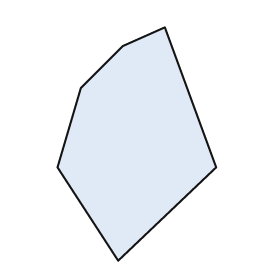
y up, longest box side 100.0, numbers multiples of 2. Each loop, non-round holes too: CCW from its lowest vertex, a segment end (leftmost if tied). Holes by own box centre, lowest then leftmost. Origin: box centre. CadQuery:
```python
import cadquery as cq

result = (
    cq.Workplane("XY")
    .moveTo(-8.0, -50.0)
    .lineTo(34.0, -10.0)
    .lineTo(12.0, 50.0)
    .lineTo(-6.0, 42.0)
    .lineTo(-24.0, 24.0)
    .lineTo(-34.0, -10.0)
    .close()
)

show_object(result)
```